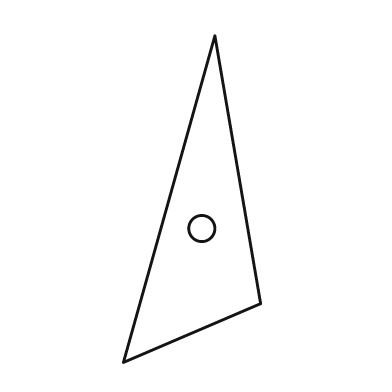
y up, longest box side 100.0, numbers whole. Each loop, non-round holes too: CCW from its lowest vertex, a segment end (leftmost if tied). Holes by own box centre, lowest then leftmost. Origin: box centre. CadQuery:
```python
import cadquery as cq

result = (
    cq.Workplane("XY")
    .moveTo(-21.0, -50.0)
    .lineTo(21.0, -32.0)
    .lineTo(7.0, 50.0)
    .close()
    .moveTo(3.0, -9.0)
    .circle(4.0)
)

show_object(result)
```